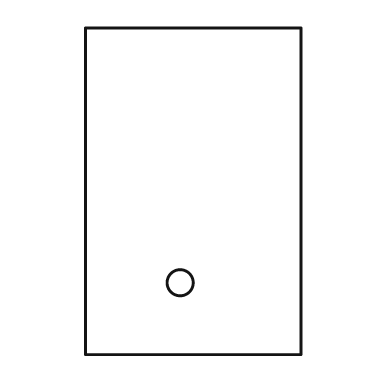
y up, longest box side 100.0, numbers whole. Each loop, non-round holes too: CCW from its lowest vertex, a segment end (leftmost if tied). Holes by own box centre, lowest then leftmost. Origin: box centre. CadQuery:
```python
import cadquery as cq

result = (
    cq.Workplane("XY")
    .moveTo(-33.0, -50.0)
    .lineTo(33.0, -50.0)
    .lineTo(33.0, 50.0)
    .lineTo(-33.0, 50.0)
    .close()
    .moveTo(-4.0, -28.0)
    .circle(4.0)
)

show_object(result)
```